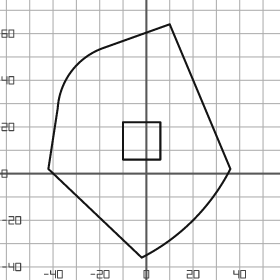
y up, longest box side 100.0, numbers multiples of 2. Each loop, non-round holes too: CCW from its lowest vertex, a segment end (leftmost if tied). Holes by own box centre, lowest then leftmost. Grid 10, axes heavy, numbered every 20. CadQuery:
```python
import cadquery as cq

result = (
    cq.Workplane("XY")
    .moveTo(-2.0, -36.0)
    .threePointArc((20.0, -20.0), (36.0, 2.0))
    .lineTo(10.0, 64.0)
    .lineTo(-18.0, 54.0)
    .threePointArc((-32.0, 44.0), (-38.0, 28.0))
    .lineTo(-42.0, 2.0)
    .close()
    .moveTo(-10.0, 6.0)
    .lineTo(6.0, 6.0)
    .lineTo(6.0, 22.0)
    .lineTo(-10.0, 22.0)
    .close()
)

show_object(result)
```